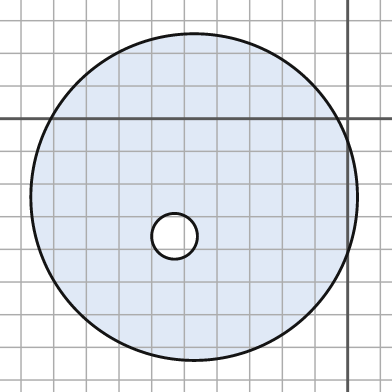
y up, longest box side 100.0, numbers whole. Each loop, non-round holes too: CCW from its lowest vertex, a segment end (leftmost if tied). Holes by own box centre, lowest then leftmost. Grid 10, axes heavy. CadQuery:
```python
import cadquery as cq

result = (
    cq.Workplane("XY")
    .moveTo(-47.0, -24.0)
    .circle(50.0)
    .moveTo(-53.0, -36.0)
    .circle(7.0)
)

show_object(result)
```